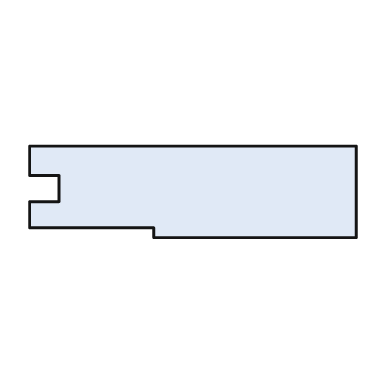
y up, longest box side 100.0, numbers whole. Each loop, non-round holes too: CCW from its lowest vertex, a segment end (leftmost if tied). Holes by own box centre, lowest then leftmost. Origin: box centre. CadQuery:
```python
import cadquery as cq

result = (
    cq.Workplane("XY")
    .moveTo(-12.0, -14.0)
    .lineTo(50.0, -14.0)
    .lineTo(50.0, 14.0)
    .lineTo(-50.0, 14.0)
    .lineTo(-50.0, 5.0)
    .lineTo(-41.0, 5.0)
    .lineTo(-41.0, -3.0)
    .lineTo(-50.0, -3.0)
    .lineTo(-50.0, -11.0)
    .lineTo(-12.0, -11.0)
    .close()
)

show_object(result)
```